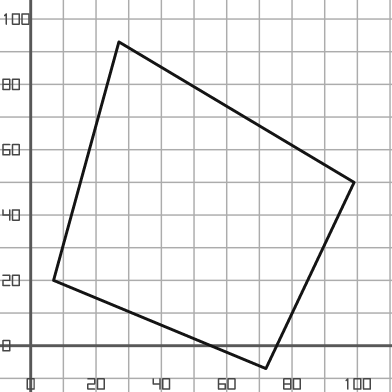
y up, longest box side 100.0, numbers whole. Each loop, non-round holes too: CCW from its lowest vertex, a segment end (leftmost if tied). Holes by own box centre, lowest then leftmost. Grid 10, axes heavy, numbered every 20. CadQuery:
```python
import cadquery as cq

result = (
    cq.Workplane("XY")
    .moveTo(72.0, -7.0)
    .lineTo(99.0, 50.0)
    .lineTo(27.0, 93.0)
    .lineTo(7.0, 20.0)
    .close()
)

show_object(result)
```